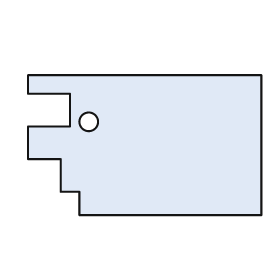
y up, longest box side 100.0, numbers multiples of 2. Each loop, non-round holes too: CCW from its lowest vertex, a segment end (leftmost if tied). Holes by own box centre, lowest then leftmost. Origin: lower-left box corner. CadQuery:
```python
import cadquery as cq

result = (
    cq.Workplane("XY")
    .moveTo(22.0, 0.0)
    .lineTo(100.0, 0.0)
    .lineTo(100.0, 60.0)
    .lineTo(0.0, 60.0)
    .lineTo(0.0, 52.0)
    .lineTo(18.0, 52.0)
    .lineTo(18.0, 38.0)
    .lineTo(0.0, 38.0)
    .lineTo(0.0, 24.0)
    .lineTo(14.0, 24.0)
    .lineTo(14.0, 10.0)
    .lineTo(22.0, 10.0)
    .close()
    .moveTo(26.0, 40.0)
    .circle(4.0)
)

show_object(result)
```